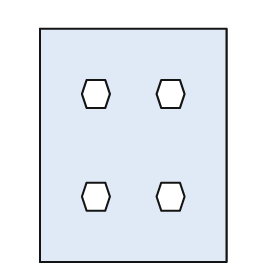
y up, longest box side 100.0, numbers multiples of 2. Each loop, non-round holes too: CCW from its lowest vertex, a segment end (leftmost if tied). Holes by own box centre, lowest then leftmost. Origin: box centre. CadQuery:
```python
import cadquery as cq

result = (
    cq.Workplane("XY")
    .moveTo(-40.0, -50.0)
    .lineTo(40.0, -50.0)
    .lineTo(40.0, 50.0)
    .lineTo(-40.0, 50.0)
    .close()
    .moveTo(-20.0, -28.0)
    .lineTo(-12.0, -28.0)
    .lineTo(-10.0, -22.0)
    .lineTo(-12.0, -16.0)
    .lineTo(-20.0, -16.0)
    .lineTo(-22.0, -22.0)
    .close()
    .moveTo(12.0, -28.0)
    .lineTo(20.0, -28.0)
    .lineTo(22.0, -22.0)
    .lineTo(20.0, -16.0)
    .lineTo(12.0, -16.0)
    .lineTo(10.0, -22.0)
    .close()
    .moveTo(-20.0, 16.0)
    .lineTo(-12.0, 16.0)
    .lineTo(-10.0, 22.0)
    .lineTo(-12.0, 28.0)
    .lineTo(-20.0, 28.0)
    .lineTo(-22.0, 22.0)
    .close()
    .moveTo(12.0, 16.0)
    .lineTo(20.0, 16.0)
    .lineTo(22.0, 22.0)
    .lineTo(20.0, 28.0)
    .lineTo(12.0, 28.0)
    .lineTo(10.0, 22.0)
    .close()
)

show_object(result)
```